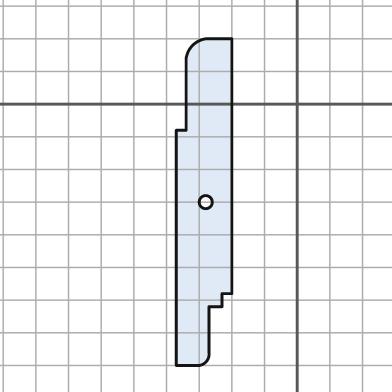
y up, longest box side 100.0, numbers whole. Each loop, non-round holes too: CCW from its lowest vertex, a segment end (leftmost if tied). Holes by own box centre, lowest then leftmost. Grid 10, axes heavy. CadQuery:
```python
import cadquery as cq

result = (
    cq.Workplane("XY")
    .moveTo(-37.0, -80.0)
    .lineTo(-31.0, -80.0)
    .threePointArc((-28.0, -79.0), (-27.0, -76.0))
    .lineTo(-27.0, -62.0)
    .lineTo(-23.0, -62.0)
    .lineTo(-23.0, -58.0)
    .lineTo(-20.0, -58.0)
    .lineTo(-20.0, 20.0)
    .lineTo(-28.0, 20.0)
    .threePointArc((-32.0, 18.0), (-34.0, 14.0))
    .lineTo(-34.0, -8.0)
    .lineTo(-37.0, -8.0)
    .close()
    .moveTo(-28.0, -30.0)
    .circle(2.0)
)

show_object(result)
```